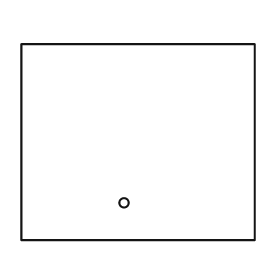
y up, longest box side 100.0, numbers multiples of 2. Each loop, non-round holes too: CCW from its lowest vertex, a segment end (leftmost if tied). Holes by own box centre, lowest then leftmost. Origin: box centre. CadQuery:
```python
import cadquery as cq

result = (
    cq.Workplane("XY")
    .moveTo(-50.0, -42.0)
    .lineTo(50.0, -42.0)
    .lineTo(50.0, 42.0)
    .lineTo(-50.0, 42.0)
    .close()
    .moveTo(-6.0, -26.0)
    .circle(2.0)
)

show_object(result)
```